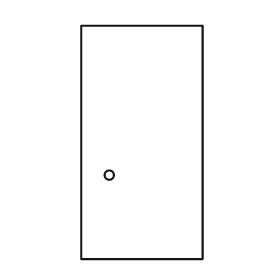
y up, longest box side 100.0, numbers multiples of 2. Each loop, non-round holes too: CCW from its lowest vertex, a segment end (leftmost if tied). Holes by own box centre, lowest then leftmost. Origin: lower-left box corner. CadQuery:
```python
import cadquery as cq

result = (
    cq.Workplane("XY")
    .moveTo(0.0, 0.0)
    .lineTo(52.0, 0.0)
    .lineTo(52.0, 100.0)
    .lineTo(0.0, 100.0)
    .close()
    .moveTo(12.0, 36.0)
    .circle(2.0)
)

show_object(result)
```